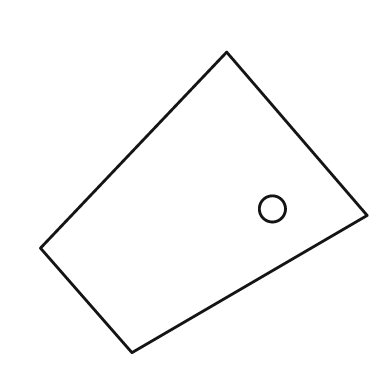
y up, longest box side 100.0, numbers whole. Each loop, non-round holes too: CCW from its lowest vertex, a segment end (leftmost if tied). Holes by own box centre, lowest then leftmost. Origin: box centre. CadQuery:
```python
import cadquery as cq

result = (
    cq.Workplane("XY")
    .moveTo(-22.0, -46.0)
    .lineTo(50.0, -4.0)
    .lineTo(7.0, 46.0)
    .lineTo(-50.0, -14.0)
    .close()
    .moveTo(21.0, -2.0)
    .circle(4.0)
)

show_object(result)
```